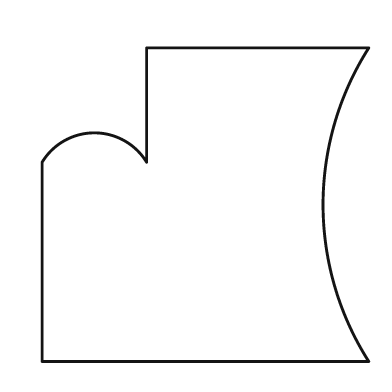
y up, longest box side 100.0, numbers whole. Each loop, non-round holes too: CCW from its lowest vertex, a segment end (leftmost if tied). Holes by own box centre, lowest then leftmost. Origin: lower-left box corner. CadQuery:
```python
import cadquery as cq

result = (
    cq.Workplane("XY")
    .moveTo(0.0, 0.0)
    .lineTo(100.0, 0.0)
    .threePointArc((86.0, 48.0), (100.0, 96.0))
    .lineTo(32.0, 96.0)
    .lineTo(32.0, 61.0)
    .threePointArc((16.0, 70.0), (0.0, 61.0))
    .close()
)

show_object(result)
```